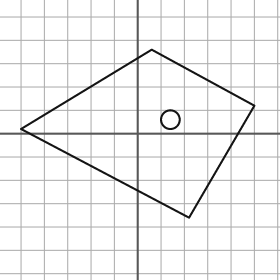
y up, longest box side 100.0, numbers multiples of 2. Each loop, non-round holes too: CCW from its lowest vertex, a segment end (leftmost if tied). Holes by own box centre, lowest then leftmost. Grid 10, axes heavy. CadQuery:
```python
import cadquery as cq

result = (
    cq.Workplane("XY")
    .moveTo(22.0, -36.0)
    .lineTo(50.0, 12.0)
    .lineTo(6.0, 36.0)
    .lineTo(-50.0, 2.0)
    .close()
    .moveTo(14.0, 6.0)
    .circle(4.0)
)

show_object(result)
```